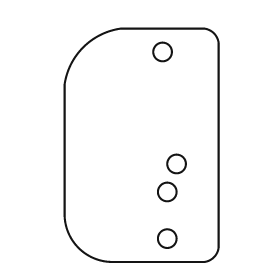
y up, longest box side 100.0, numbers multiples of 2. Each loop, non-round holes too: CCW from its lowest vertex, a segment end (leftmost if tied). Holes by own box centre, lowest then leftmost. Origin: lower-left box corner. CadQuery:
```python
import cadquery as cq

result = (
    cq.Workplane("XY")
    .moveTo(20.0, 0.0)
    .lineTo(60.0, 0.0)
    .threePointArc((64.0, 2.0), (66.0, 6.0))
    .lineTo(66.0, 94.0)
    .threePointArc((64.0, 98.0), (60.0, 100.0))
    .lineTo(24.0, 100.0)
    .threePointArc((8.0, 92.0), (0.0, 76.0))
    .lineTo(0.0, 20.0)
    .threePointArc((6.0, 6.0), (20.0, 0.0))
    .close()
    .moveTo(44.0, 10.0)
    .circle(4.0)
    .moveTo(44.0, 30.0)
    .circle(4.0)
    .moveTo(48.0, 42.0)
    .circle(4.0)
    .moveTo(42.0, 90.0)
    .circle(4.0)
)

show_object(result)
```